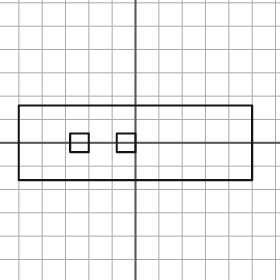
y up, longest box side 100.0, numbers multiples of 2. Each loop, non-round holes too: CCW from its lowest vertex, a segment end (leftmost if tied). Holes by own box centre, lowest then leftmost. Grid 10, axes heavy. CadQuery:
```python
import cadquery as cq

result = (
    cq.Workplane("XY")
    .moveTo(-50.0, -16.0)
    .lineTo(50.0, -16.0)
    .lineTo(50.0, 16.0)
    .lineTo(-50.0, 16.0)
    .close()
    .moveTo(-28.0, -4.0)
    .lineTo(-20.0, -4.0)
    .lineTo(-20.0, 4.0)
    .lineTo(-28.0, 4.0)
    .close()
    .moveTo(-8.0, -4.0)
    .lineTo(0.0, -4.0)
    .lineTo(0.0, 4.0)
    .lineTo(-8.0, 4.0)
    .close()
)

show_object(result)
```